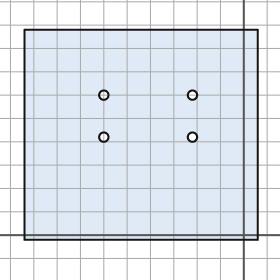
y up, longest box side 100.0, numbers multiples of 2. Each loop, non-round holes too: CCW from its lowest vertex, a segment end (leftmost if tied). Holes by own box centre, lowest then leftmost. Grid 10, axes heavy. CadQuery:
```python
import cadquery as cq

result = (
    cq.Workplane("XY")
    .moveTo(-94.0, -2.0)
    .lineTo(6.0, -2.0)
    .lineTo(6.0, 88.0)
    .lineTo(-94.0, 88.0)
    .close()
    .moveTo(-60.0, 42.0)
    .circle(2.0)
    .moveTo(-22.0, 42.0)
    .circle(2.0)
    .moveTo(-60.0, 60.0)
    .circle(2.0)
    .moveTo(-22.0, 60.0)
    .circle(2.0)
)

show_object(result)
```